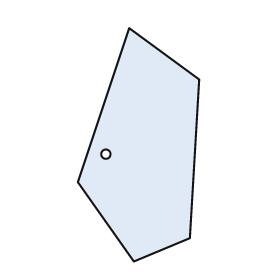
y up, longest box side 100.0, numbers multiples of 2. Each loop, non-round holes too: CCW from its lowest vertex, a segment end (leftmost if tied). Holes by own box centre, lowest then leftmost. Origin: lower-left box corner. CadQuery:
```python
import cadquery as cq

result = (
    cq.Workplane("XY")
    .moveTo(24.0, 0.0)
    .lineTo(48.0, 10.0)
    .lineTo(52.0, 78.0)
    .lineTo(22.0, 100.0)
    .lineTo(0.0, 34.0)
    .close()
    .moveTo(12.0, 46.0)
    .circle(2.0)
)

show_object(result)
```